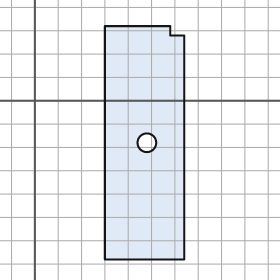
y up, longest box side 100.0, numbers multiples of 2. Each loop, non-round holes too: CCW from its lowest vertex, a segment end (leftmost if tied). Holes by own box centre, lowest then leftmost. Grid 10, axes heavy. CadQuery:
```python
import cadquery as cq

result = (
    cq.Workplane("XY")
    .moveTo(30.0, -68.0)
    .lineTo(64.0, -68.0)
    .lineTo(64.0, 28.0)
    .lineTo(58.0, 28.0)
    .lineTo(58.0, 32.0)
    .lineTo(30.0, 32.0)
    .close()
    .moveTo(48.0, -18.0)
    .circle(4.0)
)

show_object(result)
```